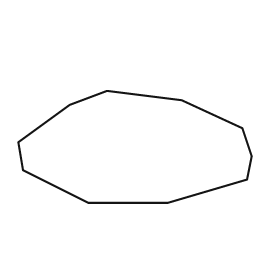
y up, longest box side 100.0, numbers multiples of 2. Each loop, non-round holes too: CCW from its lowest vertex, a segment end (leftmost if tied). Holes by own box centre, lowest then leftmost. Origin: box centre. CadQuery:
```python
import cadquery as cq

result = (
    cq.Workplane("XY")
    .moveTo(-20.0, -24.0)
    .lineTo(14.0, -24.0)
    .lineTo(48.0, -14.0)
    .lineTo(50.0, -4.0)
    .lineTo(46.0, 8.0)
    .lineTo(20.0, 20.0)
    .lineTo(-12.0, 24.0)
    .lineTo(-28.0, 18.0)
    .lineTo(-50.0, 2.0)
    .lineTo(-48.0, -10.0)
    .close()
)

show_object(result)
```